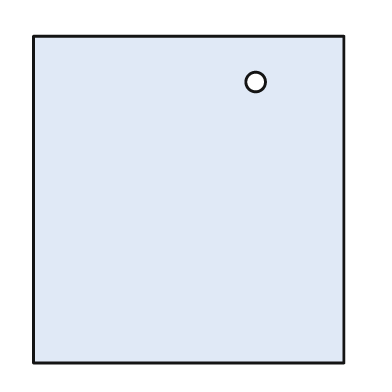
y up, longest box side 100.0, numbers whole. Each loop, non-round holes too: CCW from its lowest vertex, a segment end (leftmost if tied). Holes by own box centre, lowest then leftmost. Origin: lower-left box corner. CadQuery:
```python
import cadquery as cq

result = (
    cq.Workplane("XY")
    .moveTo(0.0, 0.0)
    .lineTo(95.0, 0.0)
    .lineTo(95.0, 100.0)
    .lineTo(0.0, 100.0)
    .close()
    .moveTo(68.0, 86.0)
    .circle(3.0)
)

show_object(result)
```